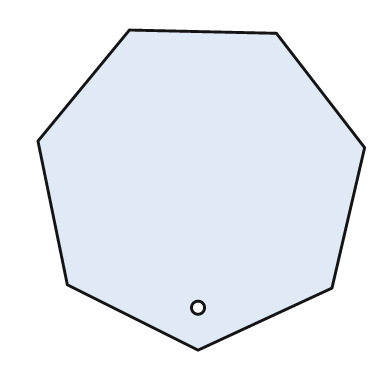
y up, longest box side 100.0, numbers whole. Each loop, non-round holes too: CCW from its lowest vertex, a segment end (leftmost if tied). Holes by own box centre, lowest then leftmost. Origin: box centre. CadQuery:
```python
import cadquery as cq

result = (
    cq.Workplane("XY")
    .moveTo(-1.0, -49.0)
    .lineTo(40.0, -30.0)
    .lineTo(50.0, 13.0)
    .lineTo(23.0, 48.0)
    .lineTo(-22.0, 49.0)
    .lineTo(-50.0, 15.0)
    .lineTo(-41.0, -29.0)
    .close()
    .moveTo(-1.0, -36.0)
    .circle(2.0)
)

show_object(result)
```